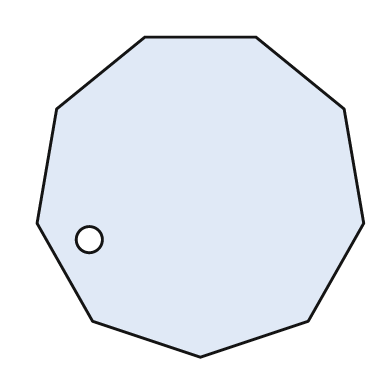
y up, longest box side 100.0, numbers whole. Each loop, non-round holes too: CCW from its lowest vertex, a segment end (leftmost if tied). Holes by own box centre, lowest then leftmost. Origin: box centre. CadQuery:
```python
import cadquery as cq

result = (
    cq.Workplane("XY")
    .moveTo(0.0, -49.0)
    .lineTo(33.0, -38.0)
    .lineTo(50.0, -8.0)
    .lineTo(44.0, 27.0)
    .lineTo(17.0, 49.0)
    .lineTo(-17.0, 49.0)
    .lineTo(-44.0, 27.0)
    .lineTo(-50.0, -8.0)
    .lineTo(-33.0, -38.0)
    .close()
    .moveTo(-34.0, -13.0)
    .circle(4.0)
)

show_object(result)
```